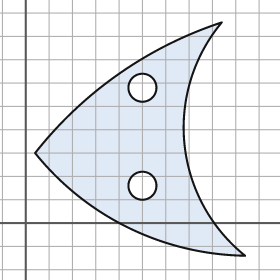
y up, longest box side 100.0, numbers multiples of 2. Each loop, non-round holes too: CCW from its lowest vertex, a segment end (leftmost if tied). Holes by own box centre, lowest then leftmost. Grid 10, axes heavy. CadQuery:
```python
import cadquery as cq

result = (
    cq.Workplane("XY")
    .moveTo(94.0, -14.0)
    .threePointArc((68.0, 34.0), (84.0, 86.0))
    .threePointArc((40.0, 64.0), (4.0, 30.0))
    .threePointArc((44.0, -2.0), (94.0, -14.0))
    .close()
    .moveTo(50.0, 16.0)
    .circle(6.0)
    .moveTo(50.0, 58.0)
    .circle(6.0)
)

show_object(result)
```